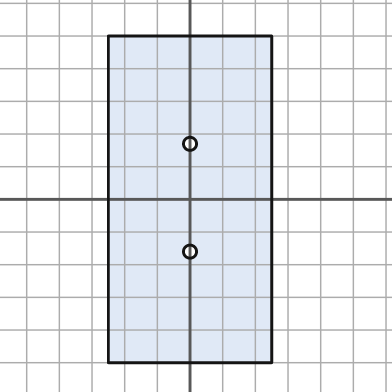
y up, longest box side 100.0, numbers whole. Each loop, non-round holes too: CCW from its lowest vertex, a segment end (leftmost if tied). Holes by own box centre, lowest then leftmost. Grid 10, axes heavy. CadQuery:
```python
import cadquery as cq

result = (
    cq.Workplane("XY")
    .moveTo(-25.0, -50.0)
    .lineTo(25.0, -50.0)
    .lineTo(25.0, 50.0)
    .lineTo(-25.0, 50.0)
    .close()
    .moveTo(0.0, -16.0)
    .circle(2.0)
    .moveTo(0.0, 17.0)
    .circle(2.0)
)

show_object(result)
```